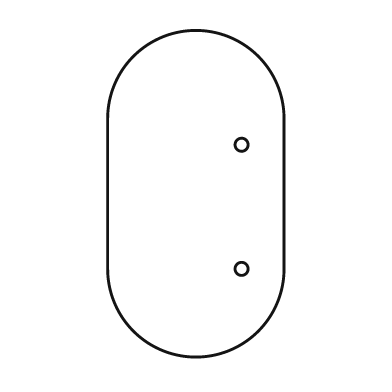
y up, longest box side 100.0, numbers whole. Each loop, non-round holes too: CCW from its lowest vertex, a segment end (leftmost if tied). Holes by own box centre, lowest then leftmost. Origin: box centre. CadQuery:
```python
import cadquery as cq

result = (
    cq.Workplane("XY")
    .moveTo(-27.0, -23.0)
    .threePointArc((0.0, -50.0), (27.0, -23.0))
    .lineTo(27.0, 23.0)
    .threePointArc((0.0, 50.0), (-27.0, 23.0))
    .close()
    .moveTo(14.0, -23.0)
    .circle(2.0)
    .moveTo(14.0, 15.0)
    .circle(2.0)
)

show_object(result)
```